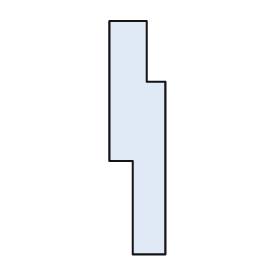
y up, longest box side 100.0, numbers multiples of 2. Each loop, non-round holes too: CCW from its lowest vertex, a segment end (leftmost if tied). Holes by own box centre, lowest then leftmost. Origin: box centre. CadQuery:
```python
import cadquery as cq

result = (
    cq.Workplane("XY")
    .moveTo(-2.0, -50.0)
    .lineTo(12.0, -50.0)
    .lineTo(12.0, 24.0)
    .lineTo(4.0, 24.0)
    .lineTo(4.0, 50.0)
    .lineTo(-12.0, 50.0)
    .lineTo(-12.0, -10.0)
    .lineTo(-2.0, -10.0)
    .close()
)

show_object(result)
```